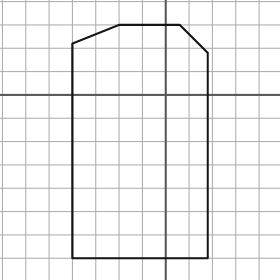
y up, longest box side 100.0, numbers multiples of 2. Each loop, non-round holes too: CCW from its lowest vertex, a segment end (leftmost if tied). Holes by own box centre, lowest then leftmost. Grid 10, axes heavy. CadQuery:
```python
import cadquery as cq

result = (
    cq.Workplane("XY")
    .moveTo(-40.0, -70.0)
    .lineTo(18.0, -70.0)
    .lineTo(18.0, 18.0)
    .lineTo(6.0, 30.0)
    .lineTo(-20.0, 30.0)
    .lineTo(-40.0, 22.0)
    .close()
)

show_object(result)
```